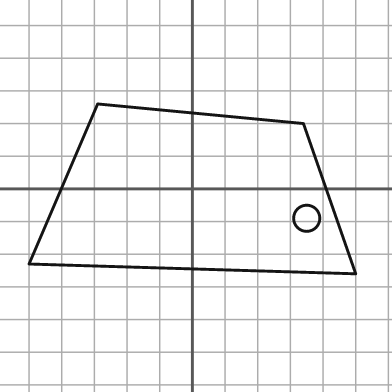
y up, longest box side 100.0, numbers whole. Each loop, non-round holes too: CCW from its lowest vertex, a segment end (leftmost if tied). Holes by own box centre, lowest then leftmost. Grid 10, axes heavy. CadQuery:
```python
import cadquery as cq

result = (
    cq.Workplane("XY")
    .moveTo(50.0, -26.0)
    .lineTo(34.0, 20.0)
    .lineTo(-29.0, 26.0)
    .lineTo(-50.0, -23.0)
    .close()
    .moveTo(35.0, -9.0)
    .circle(4.0)
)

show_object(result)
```